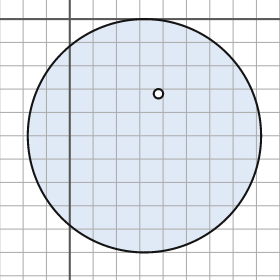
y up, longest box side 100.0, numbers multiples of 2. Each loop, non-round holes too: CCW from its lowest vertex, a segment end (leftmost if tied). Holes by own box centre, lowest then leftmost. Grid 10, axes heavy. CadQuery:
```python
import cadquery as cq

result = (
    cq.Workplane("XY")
    .moveTo(32.0, -50.0)
    .circle(50.0)
    .moveTo(38.0, -32.0)
    .circle(2.0)
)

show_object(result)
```